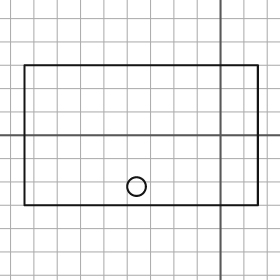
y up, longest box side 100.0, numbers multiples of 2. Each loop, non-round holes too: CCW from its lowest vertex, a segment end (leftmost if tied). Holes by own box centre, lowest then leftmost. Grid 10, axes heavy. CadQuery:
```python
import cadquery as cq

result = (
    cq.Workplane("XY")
    .moveTo(-84.0, -30.0)
    .lineTo(16.0, -30.0)
    .lineTo(16.0, 30.0)
    .lineTo(-84.0, 30.0)
    .close()
    .moveTo(-36.0, -22.0)
    .circle(4.0)
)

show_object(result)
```